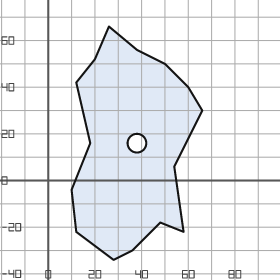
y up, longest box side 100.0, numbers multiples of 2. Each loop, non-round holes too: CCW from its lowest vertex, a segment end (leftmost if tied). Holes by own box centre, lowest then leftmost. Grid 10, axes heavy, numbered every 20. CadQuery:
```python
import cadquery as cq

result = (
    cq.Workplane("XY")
    .moveTo(28.0, -34.0)
    .lineTo(36.0, -30.0)
    .lineTo(48.0, -18.0)
    .lineTo(58.0, -22.0)
    .lineTo(54.0, 6.0)
    .lineTo(66.0, 30.0)
    .lineTo(60.0, 40.0)
    .lineTo(50.0, 50.0)
    .lineTo(38.0, 56.0)
    .lineTo(26.0, 66.0)
    .lineTo(20.0, 52.0)
    .lineTo(12.0, 42.0)
    .lineTo(18.0, 16.0)
    .lineTo(10.0, -4.0)
    .lineTo(12.0, -22.0)
    .close()
    .moveTo(38.0, 16.0)
    .circle(4.0)
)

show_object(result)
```